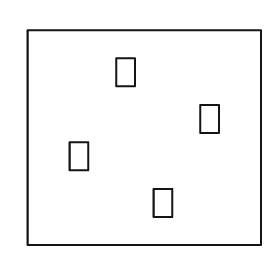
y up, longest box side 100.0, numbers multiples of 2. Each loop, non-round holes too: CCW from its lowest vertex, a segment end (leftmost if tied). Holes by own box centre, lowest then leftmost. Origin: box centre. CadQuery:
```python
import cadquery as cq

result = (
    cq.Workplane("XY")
    .moveTo(-50.0, -46.0)
    .lineTo(50.0, -46.0)
    .lineTo(50.0, 46.0)
    .lineTo(-50.0, 46.0)
    .close()
    .moveTo(4.0, -34.0)
    .lineTo(12.0, -34.0)
    .lineTo(12.0, -22.0)
    .lineTo(4.0, -22.0)
    .close()
    .moveTo(-32.0, -14.0)
    .lineTo(-24.0, -14.0)
    .lineTo(-24.0, -2.0)
    .lineTo(-32.0, -2.0)
    .close()
    .moveTo(24.0, 2.0)
    .lineTo(32.0, 2.0)
    .lineTo(32.0, 14.0)
    .lineTo(24.0, 14.0)
    .close()
    .moveTo(-12.0, 22.0)
    .lineTo(-4.0, 22.0)
    .lineTo(-4.0, 34.0)
    .lineTo(-12.0, 34.0)
    .close()
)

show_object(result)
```